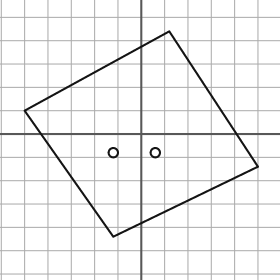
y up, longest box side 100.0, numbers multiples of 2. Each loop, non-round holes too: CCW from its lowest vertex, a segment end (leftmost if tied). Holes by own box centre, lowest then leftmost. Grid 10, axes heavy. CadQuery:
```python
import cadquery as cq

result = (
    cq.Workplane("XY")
    .moveTo(-12.0, -44.0)
    .lineTo(50.0, -14.0)
    .lineTo(12.0, 44.0)
    .lineTo(-50.0, 10.0)
    .close()
    .moveTo(-12.0, -8.0)
    .circle(2.0)
    .moveTo(6.0, -8.0)
    .circle(2.0)
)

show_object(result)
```